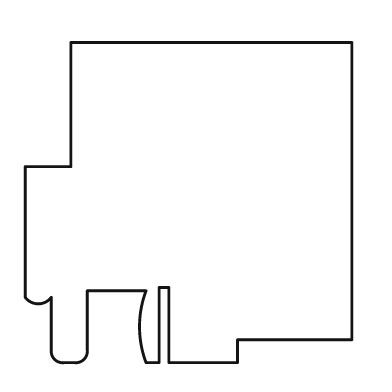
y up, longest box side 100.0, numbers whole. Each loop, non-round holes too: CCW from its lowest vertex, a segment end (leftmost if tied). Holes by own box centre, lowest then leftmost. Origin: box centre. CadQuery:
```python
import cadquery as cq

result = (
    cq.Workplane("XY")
    .moveTo(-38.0, -49.0)
    .lineTo(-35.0, -49.0)
    .threePointArc((-32.0, -48.0), (-31.0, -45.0))
    .lineTo(-31.0, -27.0)
    .lineTo(-13.0, -27.0)
    .threePointArc((-15.0, -38.0), (-13.0, -49.0))
    .lineTo(-9.0, -49.0)
    .lineTo(-9.0, -26.0)
    .lineTo(-6.0, -26.0)
    .lineTo(-6.0, -49.0)
    .lineTo(15.0, -49.0)
    .lineTo(15.0, -42.0)
    .lineTo(50.0, -42.0)
    .lineTo(50.0, 49.0)
    .lineTo(-36.0, 49.0)
    .lineTo(-36.0, 11.0)
    .lineTo(-50.0, 11.0)
    .lineTo(-50.0, -29.0)
    .threePointArc((-46.0, -31.0), (-42.0, -29.0))
    .lineTo(-42.0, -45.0)
    .threePointArc((-41.0, -48.0), (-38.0, -49.0))
    .close()
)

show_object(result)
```